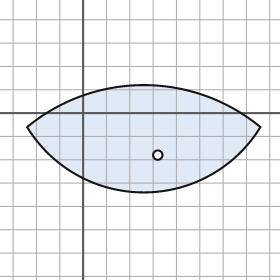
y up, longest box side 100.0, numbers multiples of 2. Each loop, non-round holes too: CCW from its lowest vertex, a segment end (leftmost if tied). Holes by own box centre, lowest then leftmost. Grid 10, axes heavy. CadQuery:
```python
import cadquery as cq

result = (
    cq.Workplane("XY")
    .moveTo(-24.0, -6.0)
    .threePointArc((26.0, -34.0), (76.0, -6.0))
    .threePointArc((26.0, 12.0), (-24.0, -6.0))
    .close()
    .moveTo(32.0, -18.0)
    .circle(2.0)
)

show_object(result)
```